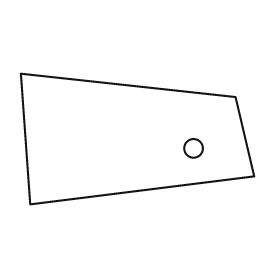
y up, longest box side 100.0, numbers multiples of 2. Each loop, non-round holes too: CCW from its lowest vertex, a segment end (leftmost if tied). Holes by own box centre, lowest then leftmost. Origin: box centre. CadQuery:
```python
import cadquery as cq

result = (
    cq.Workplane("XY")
    .moveTo(-46.0, -28.0)
    .lineTo(50.0, -16.0)
    .lineTo(42.0, 18.0)
    .lineTo(-50.0, 28.0)
    .close()
    .moveTo(24.0, -4.0)
    .circle(4.0)
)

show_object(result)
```